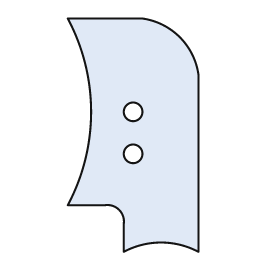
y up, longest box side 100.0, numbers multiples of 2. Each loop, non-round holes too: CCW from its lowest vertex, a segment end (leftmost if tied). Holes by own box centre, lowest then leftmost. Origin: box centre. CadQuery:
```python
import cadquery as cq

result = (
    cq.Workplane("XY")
    .moveTo(-4.0, -50.0)
    .threePointArc((12.0, -46.0), (28.0, -50.0))
    .lineTo(28.0, 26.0)
    .threePointArc((20.0, 42.0), (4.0, 50.0))
    .lineTo(-28.0, 50.0)
    .threePointArc((-18.0, 10.0), (-28.0, -30.0))
    .lineTo(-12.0, -30.0)
    .threePointArc((-6.0, -32.0), (-4.0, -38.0))
    .close()
    .moveTo(0.0, -8.0)
    .circle(4.0)
    .moveTo(0.0, 10.0)
    .circle(4.0)
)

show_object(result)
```